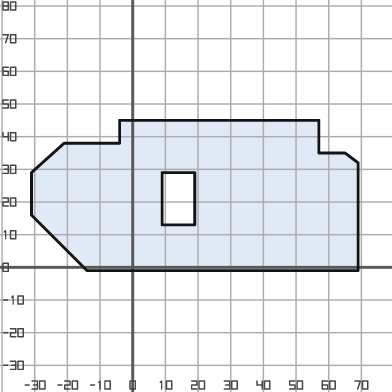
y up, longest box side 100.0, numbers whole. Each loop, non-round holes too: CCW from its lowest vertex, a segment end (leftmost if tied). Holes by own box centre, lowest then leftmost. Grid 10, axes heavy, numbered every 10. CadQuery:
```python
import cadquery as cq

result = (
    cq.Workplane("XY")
    .moveTo(-14.0, -1.0)
    .lineTo(69.0, -1.0)
    .lineTo(69.0, 32.0)
    .lineTo(65.0, 35.0)
    .lineTo(57.0, 35.0)
    .lineTo(57.0, 45.0)
    .lineTo(-4.0, 45.0)
    .lineTo(-4.0, 38.0)
    .lineTo(-21.0, 38.0)
    .lineTo(-31.0, 29.0)
    .lineTo(-31.0, 16.0)
    .close()
    .moveTo(9.0, 13.0)
    .lineTo(19.0, 13.0)
    .lineTo(19.0, 29.0)
    .lineTo(9.0, 29.0)
    .close()
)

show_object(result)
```